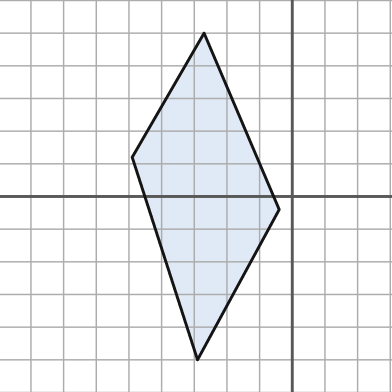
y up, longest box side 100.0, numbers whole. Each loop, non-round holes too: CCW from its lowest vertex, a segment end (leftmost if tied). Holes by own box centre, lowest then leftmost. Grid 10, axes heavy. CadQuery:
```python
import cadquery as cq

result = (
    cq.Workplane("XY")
    .moveTo(-29.0, -50.0)
    .lineTo(-4.0, -4.0)
    .lineTo(-27.0, 50.0)
    .lineTo(-49.0, 12.0)
    .close()
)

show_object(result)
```